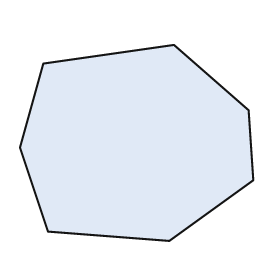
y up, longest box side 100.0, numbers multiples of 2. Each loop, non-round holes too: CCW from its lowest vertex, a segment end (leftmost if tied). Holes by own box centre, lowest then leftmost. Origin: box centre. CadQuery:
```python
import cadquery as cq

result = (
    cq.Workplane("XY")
    .moveTo(14.0, -42.0)
    .lineTo(50.0, -16.0)
    .lineTo(48.0, 14.0)
    .lineTo(16.0, 42.0)
    .lineTo(-40.0, 34.0)
    .lineTo(-50.0, -2.0)
    .lineTo(-38.0, -38.0)
    .close()
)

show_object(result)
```